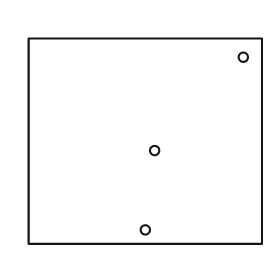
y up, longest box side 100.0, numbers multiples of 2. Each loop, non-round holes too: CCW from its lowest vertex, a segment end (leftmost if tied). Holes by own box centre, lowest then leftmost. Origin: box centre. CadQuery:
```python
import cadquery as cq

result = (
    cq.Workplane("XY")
    .moveTo(-50.0, -44.0)
    .lineTo(50.0, -44.0)
    .lineTo(50.0, 44.0)
    .lineTo(-50.0, 44.0)
    .close()
    .moveTo(0.0, -38.0)
    .circle(2.0)
    .moveTo(4.0, -4.0)
    .circle(2.0)
    .moveTo(42.0, 36.0)
    .circle(2.0)
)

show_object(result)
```